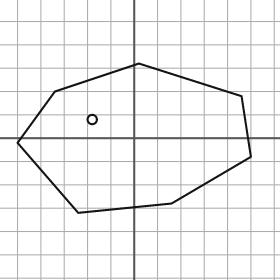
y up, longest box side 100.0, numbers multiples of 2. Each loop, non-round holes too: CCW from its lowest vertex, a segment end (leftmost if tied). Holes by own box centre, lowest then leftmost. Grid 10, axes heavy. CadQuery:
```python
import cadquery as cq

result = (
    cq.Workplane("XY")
    .moveTo(-24.0, -32.0)
    .lineTo(16.0, -28.0)
    .lineTo(50.0, -8.0)
    .lineTo(46.0, 18.0)
    .lineTo(2.0, 32.0)
    .lineTo(-34.0, 20.0)
    .lineTo(-50.0, -2.0)
    .close()
    .moveTo(-18.0, 8.0)
    .circle(2.0)
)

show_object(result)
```